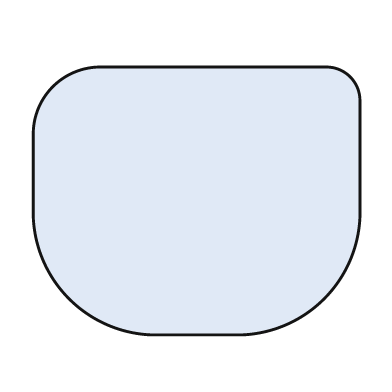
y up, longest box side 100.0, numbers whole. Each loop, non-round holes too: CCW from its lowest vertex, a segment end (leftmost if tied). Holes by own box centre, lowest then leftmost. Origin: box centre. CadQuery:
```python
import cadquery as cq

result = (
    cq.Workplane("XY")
    .moveTo(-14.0, -41.0)
    .lineTo(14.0, -41.0)
    .threePointArc((39.0, -30.0), (50.0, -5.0))
    .lineTo(50.0, 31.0)
    .threePointArc((47.0, 38.0), (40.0, 41.0))
    .lineTo(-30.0, 41.0)
    .threePointArc((-44.0, 35.0), (-50.0, 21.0))
    .lineTo(-50.0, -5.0)
    .threePointArc((-39.0, -30.0), (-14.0, -41.0))
    .close()
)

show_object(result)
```